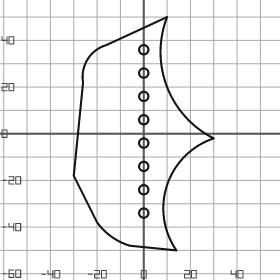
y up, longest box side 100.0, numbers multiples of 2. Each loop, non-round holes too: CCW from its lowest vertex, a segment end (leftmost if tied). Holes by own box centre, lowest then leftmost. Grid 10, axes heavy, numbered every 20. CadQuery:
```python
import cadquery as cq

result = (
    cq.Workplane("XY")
    .moveTo(14.0, -50.0)
    .threePointArc((10.0, -22.0), (30.0, -2.0))
    .threePointArc((10.0, 20.0), (10.0, 50.0))
    .lineTo(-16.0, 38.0)
    .threePointArc((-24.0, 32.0), (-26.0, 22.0))
    .lineTo(-30.0, -18.0)
    .lineTo(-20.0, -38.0)
    .threePointArc((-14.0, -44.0), (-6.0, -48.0))
    .close()
    .moveTo(0.0, -34.0)
    .circle(2.0)
    .moveTo(0.0, -24.0)
    .circle(2.0)
    .moveTo(0.0, -14.0)
    .circle(2.0)
    .moveTo(0.0, -4.0)
    .circle(2.0)
    .moveTo(0.0, 6.0)
    .circle(2.0)
    .moveTo(0.0, 16.0)
    .circle(2.0)
    .moveTo(0.0, 26.0)
    .circle(2.0)
    .moveTo(0.0, 36.0)
    .circle(2.0)
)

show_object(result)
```